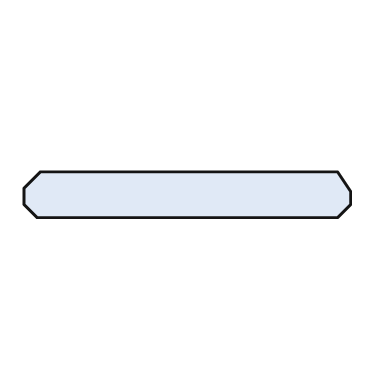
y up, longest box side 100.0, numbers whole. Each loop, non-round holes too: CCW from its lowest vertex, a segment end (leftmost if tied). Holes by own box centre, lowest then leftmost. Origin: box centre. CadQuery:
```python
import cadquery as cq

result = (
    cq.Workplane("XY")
    .moveTo(-46.0, -7.0)
    .lineTo(46.0, -7.0)
    .lineTo(50.0, -3.0)
    .lineTo(50.0, 1.0)
    .lineTo(46.0, 7.0)
    .lineTo(-45.0, 7.0)
    .lineTo(-50.0, 2.0)
    .lineTo(-50.0, -3.0)
    .close()
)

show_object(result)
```